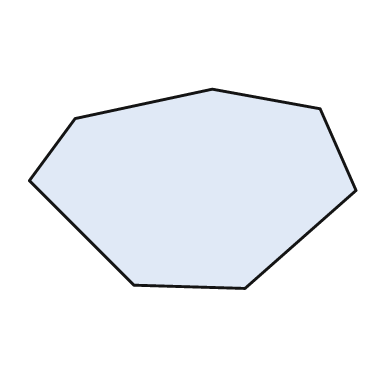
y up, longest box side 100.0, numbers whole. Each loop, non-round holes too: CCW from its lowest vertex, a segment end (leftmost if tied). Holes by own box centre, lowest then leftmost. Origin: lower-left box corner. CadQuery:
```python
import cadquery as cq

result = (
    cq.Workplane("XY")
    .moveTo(66.0, 0.0)
    .lineTo(100.0, 30.0)
    .lineTo(89.0, 55.0)
    .lineTo(56.0, 61.0)
    .lineTo(14.0, 52.0)
    .lineTo(0.0, 33.0)
    .lineTo(32.0, 1.0)
    .close()
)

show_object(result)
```